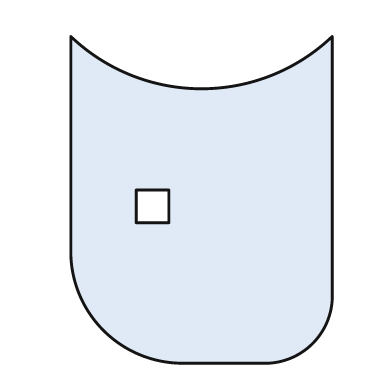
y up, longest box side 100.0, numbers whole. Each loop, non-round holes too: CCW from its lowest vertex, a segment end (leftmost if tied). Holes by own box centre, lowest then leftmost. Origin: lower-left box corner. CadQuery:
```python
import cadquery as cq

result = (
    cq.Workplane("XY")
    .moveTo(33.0, 0.0)
    .lineTo(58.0, 0.0)
    .threePointArc((74.0, 6.0), (80.0, 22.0))
    .lineTo(80.0, 100.0)
    .threePointArc((40.0, 84.0), (0.0, 100.0))
    .lineTo(0.0, 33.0)
    .threePointArc((10.0, 10.0), (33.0, 0.0))
    .close()
    .moveTo(20.0, 43.0)
    .lineTo(30.0, 43.0)
    .lineTo(30.0, 53.0)
    .lineTo(20.0, 53.0)
    .close()
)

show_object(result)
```